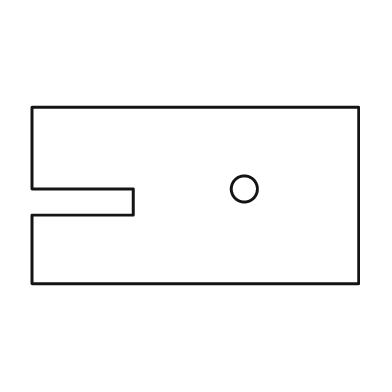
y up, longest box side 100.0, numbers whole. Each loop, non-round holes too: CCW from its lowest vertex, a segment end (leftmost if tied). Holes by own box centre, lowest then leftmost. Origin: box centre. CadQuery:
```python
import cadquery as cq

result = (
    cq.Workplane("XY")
    .moveTo(-50.0, -27.0)
    .lineTo(50.0, -27.0)
    .lineTo(50.0, 27.0)
    .lineTo(-50.0, 27.0)
    .lineTo(-50.0, 2.0)
    .lineTo(-19.0, 2.0)
    .lineTo(-19.0, -6.0)
    .lineTo(-50.0, -6.0)
    .close()
    .moveTo(15.0, 2.0)
    .circle(4.0)
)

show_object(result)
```